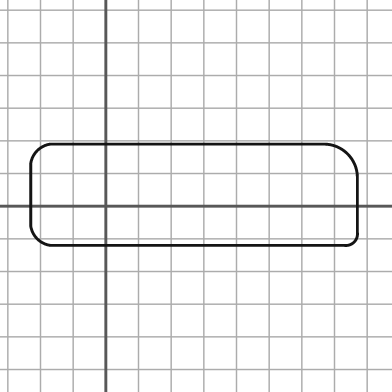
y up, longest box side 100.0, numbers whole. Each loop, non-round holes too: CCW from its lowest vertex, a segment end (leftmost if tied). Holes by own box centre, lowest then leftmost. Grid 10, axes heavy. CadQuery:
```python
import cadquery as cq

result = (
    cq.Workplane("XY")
    .moveTo(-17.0, -12.0)
    .lineTo(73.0, -12.0)
    .threePointArc((76.0, -11.0), (77.0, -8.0))
    .lineTo(77.0, 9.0)
    .threePointArc((74.0, 16.0), (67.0, 19.0))
    .lineTo(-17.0, 19.0)
    .threePointArc((-21.0, 17.0), (-23.0, 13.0))
    .lineTo(-23.0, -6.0)
    .threePointArc((-21.0, -10.0), (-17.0, -12.0))
    .close()
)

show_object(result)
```